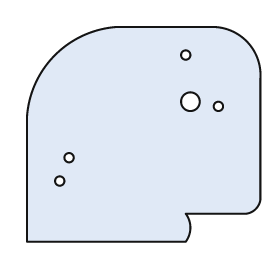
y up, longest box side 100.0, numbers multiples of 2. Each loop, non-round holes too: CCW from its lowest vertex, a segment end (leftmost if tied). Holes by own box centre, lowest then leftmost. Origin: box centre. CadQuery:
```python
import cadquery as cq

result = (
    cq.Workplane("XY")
    .moveTo(-50.0, -46.0)
    .lineTo(18.0, -46.0)
    .threePointArc((20.0, -40.0), (18.0, -34.0))
    .lineTo(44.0, -34.0)
    .threePointArc((48.0, -32.0), (50.0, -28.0))
    .lineTo(50.0, 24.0)
    .threePointArc((44.0, 40.0), (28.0, 46.0))
    .lineTo(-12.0, 46.0)
    .threePointArc((-38.0, 34.0), (-50.0, 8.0))
    .close()
    .moveTo(-36.0, -20.0)
    .circle(2.0)
    .moveTo(-32.0, -10.0)
    .circle(2.0)
    .moveTo(32.0, 12.0)
    .circle(2.0)
    .moveTo(20.0, 14.0)
    .circle(4.0)
    .moveTo(18.0, 34.0)
    .circle(2.0)
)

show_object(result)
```